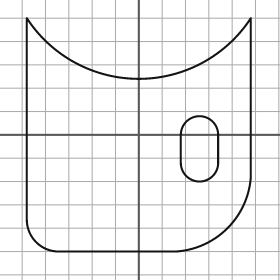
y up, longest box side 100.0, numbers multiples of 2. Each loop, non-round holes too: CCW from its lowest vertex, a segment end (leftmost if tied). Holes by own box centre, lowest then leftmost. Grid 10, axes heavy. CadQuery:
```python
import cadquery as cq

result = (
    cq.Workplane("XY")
    .moveTo(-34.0, -50.0)
    .lineTo(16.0, -50.0)
    .threePointArc((38.0, -40.0), (48.0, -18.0))
    .lineTo(48.0, 50.0)
    .threePointArc((0.0, 24.0), (-48.0, 50.0))
    .lineTo(-48.0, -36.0)
    .threePointArc((-44.0, -46.0), (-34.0, -50.0))
    .close()
    .moveTo(18.0, -12.0)
    .threePointArc((26.0, -20.0), (34.0, -12.0))
    .lineTo(34.0, 0.0)
    .threePointArc((26.0, 8.0), (18.0, 0.0))
    .close()
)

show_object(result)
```